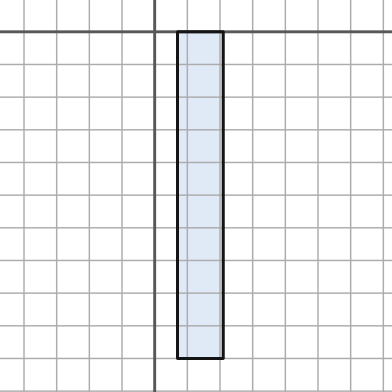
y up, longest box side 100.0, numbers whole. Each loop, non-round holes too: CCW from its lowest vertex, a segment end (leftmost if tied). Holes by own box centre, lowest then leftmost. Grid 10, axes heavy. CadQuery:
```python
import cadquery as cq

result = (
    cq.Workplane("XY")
    .moveTo(7.0, -100.0)
    .lineTo(21.0, -100.0)
    .lineTo(21.0, 0.0)
    .lineTo(7.0, 0.0)
    .close()
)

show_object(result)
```